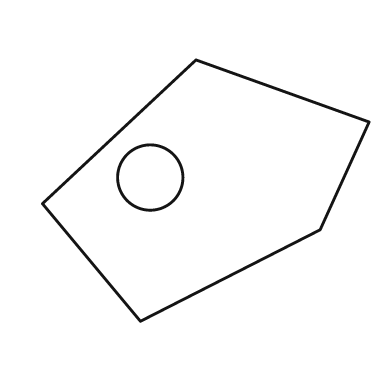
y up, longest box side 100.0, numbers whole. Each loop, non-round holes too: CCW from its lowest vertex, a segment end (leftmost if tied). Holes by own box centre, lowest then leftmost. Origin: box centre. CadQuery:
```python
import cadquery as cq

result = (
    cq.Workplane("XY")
    .moveTo(-20.0, -40.0)
    .lineTo(35.0, -12.0)
    .lineTo(50.0, 21.0)
    .lineTo(-3.0, 40.0)
    .lineTo(-50.0, -4.0)
    .close()
    .moveTo(-17.0, 4.0)
    .circle(10.0)
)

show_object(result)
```